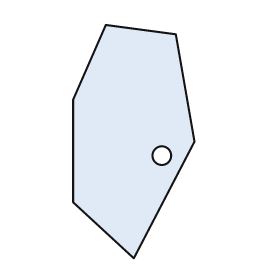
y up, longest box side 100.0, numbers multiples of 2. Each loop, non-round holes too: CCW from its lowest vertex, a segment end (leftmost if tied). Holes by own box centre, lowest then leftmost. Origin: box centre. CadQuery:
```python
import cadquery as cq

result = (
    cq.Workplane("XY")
    .moveTo(0.0, -50.0)
    .lineTo(26.0, 0.0)
    .lineTo(18.0, 46.0)
    .lineTo(-12.0, 50.0)
    .lineTo(-26.0, 18.0)
    .lineTo(-26.0, -26.0)
    .close()
    .moveTo(12.0, -6.0)
    .circle(4.0)
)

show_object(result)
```